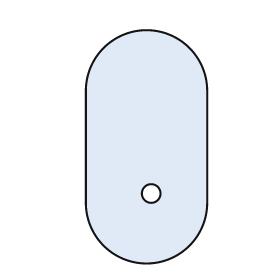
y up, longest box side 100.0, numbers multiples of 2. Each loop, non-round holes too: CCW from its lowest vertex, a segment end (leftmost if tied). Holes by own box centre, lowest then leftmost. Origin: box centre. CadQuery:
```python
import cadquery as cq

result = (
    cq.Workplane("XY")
    .moveTo(-26.0, -24.0)
    .threePointArc((0.0, -50.0), (26.0, -24.0))
    .lineTo(26.0, 24.0)
    .threePointArc((0.0, 50.0), (-26.0, 24.0))
    .close()
    .moveTo(2.0, -20.0)
    .circle(4.0)
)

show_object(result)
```